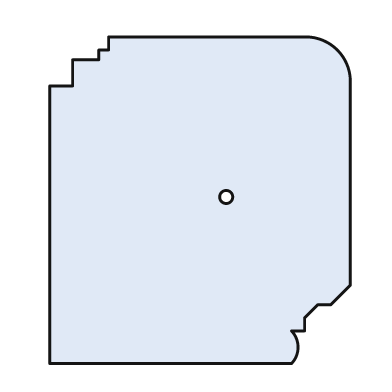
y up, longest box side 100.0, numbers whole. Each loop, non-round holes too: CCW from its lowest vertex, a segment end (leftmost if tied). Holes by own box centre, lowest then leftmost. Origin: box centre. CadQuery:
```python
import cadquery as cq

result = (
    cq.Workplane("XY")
    .moveTo(-46.0, -50.0)
    .lineTo(28.0, -50.0)
    .threePointArc((30.0, -45.0), (28.0, -40.0))
    .lineTo(32.0, -40.0)
    .lineTo(32.0, -36.0)
    .lineTo(36.0, -32.0)
    .lineTo(40.0, -32.0)
    .lineTo(46.0, -26.0)
    .lineTo(46.0, 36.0)
    .threePointArc((42.0, 46.0), (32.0, 50.0))
    .lineTo(-28.0, 50.0)
    .lineTo(-28.0, 46.0)
    .lineTo(-31.0, 46.0)
    .lineTo(-31.0, 43.0)
    .lineTo(-39.0, 43.0)
    .lineTo(-39.0, 35.0)
    .lineTo(-46.0, 35.0)
    .close()
    .moveTo(8.0, 1.0)
    .circle(2.0)
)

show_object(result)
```